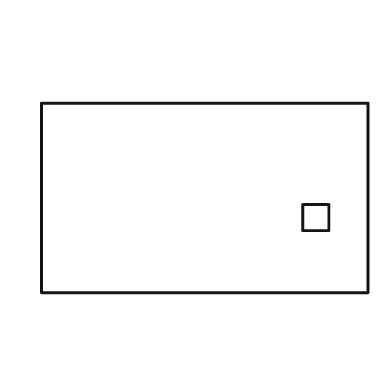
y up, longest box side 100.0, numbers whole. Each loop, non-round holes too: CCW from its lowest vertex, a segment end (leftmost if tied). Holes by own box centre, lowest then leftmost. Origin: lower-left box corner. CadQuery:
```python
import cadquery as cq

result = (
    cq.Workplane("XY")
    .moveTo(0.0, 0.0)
    .lineTo(100.0, 0.0)
    .lineTo(100.0, 58.0)
    .lineTo(0.0, 58.0)
    .close()
    .moveTo(80.0, 19.0)
    .lineTo(88.0, 19.0)
    .lineTo(88.0, 27.0)
    .lineTo(80.0, 27.0)
    .close()
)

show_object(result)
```